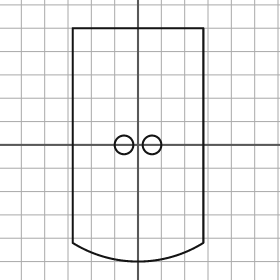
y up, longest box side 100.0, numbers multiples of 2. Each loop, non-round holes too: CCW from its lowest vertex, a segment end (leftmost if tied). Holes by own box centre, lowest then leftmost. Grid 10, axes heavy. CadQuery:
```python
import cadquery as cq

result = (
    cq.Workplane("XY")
    .moveTo(-28.0, -42.0)
    .threePointArc((0.0, -50.0), (28.0, -42.0))
    .lineTo(28.0, 50.0)
    .lineTo(-28.0, 50.0)
    .close()
    .moveTo(-6.0, 0.0)
    .circle(4.0)
    .moveTo(6.0, 0.0)
    .circle(4.0)
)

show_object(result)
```